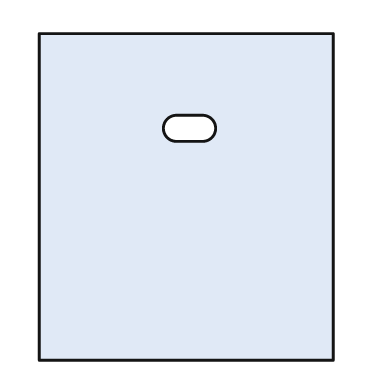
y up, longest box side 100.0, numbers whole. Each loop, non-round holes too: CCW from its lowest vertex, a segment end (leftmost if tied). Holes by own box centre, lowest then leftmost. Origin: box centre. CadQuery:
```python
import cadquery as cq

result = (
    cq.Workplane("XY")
    .moveTo(-45.0, -50.0)
    .lineTo(45.0, -50.0)
    .lineTo(45.0, 50.0)
    .lineTo(-45.0, 50.0)
    .close()
    .moveTo(-3.0, 17.0)
    .lineTo(5.0, 17.0)
    .threePointArc((9.0, 21.0), (5.0, 25.0))
    .lineTo(-3.0, 25.0)
    .threePointArc((-7.0, 21.0), (-3.0, 17.0))
    .close()
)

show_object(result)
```